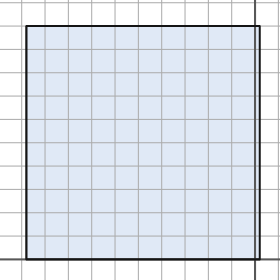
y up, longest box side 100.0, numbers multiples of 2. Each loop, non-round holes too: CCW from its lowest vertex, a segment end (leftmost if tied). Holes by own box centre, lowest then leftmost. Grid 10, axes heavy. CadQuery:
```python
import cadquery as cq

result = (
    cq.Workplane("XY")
    .moveTo(-98.0, 0.0)
    .lineTo(2.0, 0.0)
    .lineTo(2.0, 100.0)
    .lineTo(-98.0, 100.0)
    .close()
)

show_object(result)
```